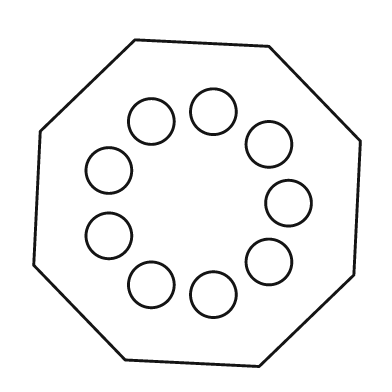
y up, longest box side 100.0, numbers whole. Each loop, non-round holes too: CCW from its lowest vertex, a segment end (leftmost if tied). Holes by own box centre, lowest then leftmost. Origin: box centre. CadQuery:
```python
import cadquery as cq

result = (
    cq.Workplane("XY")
    .moveTo(19.0, -50.0)
    .lineTo(48.0, -22.0)
    .lineTo(50.0, 19.0)
    .lineTo(22.0, 48.0)
    .lineTo(-19.0, 50.0)
    .lineTo(-48.0, 22.0)
    .lineTo(-50.0, -19.0)
    .lineTo(-22.0, -48.0)
    .close()
    .moveTo(5.0, -28.0)
    .circle(7.0)
    .moveTo(-14.0, -25.0)
    .circle(7.0)
    .moveTo(22.0, -18.0)
    .circle(7.0)
    .moveTo(-27.0, -10.0)
    .circle(7.0)
    .moveTo(28.0, 0.0)
    .circle(7.0)
    .moveTo(-27.0, 10.0)
    .circle(7.0)
    .moveTo(22.0, 18.0)
    .circle(7.0)
    .moveTo(-14.0, 25.0)
    .circle(7.0)
    .moveTo(5.0, 28.0)
    .circle(7.0)
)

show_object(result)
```